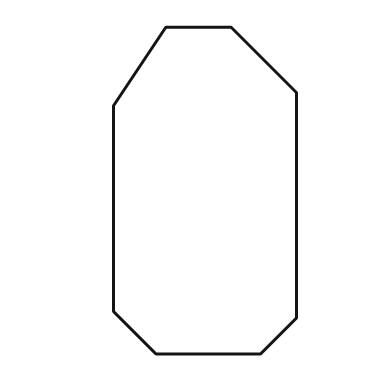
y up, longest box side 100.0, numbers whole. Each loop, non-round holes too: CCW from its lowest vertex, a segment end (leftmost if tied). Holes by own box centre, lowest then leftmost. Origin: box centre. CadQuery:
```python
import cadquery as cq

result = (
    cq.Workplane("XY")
    .moveTo(-15.0, -50.0)
    .lineTo(17.0, -50.0)
    .lineTo(28.0, -39.0)
    .lineTo(28.0, 30.0)
    .lineTo(8.0, 50.0)
    .lineTo(-12.0, 50.0)
    .lineTo(-28.0, 26.0)
    .lineTo(-28.0, -37.0)
    .close()
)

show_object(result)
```